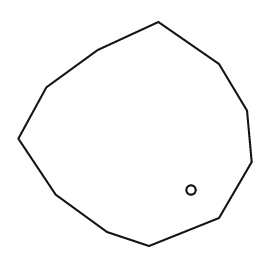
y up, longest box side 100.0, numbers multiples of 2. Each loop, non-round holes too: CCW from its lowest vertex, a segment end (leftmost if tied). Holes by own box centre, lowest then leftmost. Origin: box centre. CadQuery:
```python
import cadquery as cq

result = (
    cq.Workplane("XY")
    .moveTo(6.0, -48.0)
    .lineTo(36.0, -36.0)
    .lineTo(50.0, -12.0)
    .lineTo(48.0, 10.0)
    .lineTo(36.0, 30.0)
    .lineTo(10.0, 48.0)
    .lineTo(-16.0, 36.0)
    .lineTo(-38.0, 20.0)
    .lineTo(-50.0, -2.0)
    .lineTo(-34.0, -26.0)
    .lineTo(-12.0, -42.0)
    .close()
    .moveTo(24.0, -24.0)
    .circle(2.0)
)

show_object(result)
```